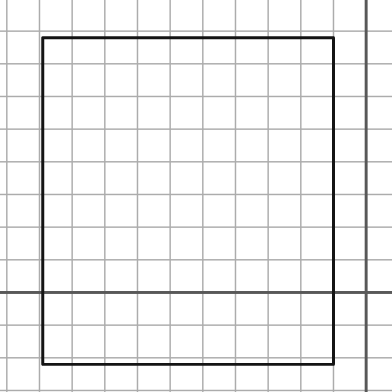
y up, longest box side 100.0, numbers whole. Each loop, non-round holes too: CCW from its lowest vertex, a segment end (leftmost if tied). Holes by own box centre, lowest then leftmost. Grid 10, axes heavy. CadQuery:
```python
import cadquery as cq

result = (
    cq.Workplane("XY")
    .moveTo(-99.0, -22.0)
    .lineTo(-10.0, -22.0)
    .lineTo(-10.0, 78.0)
    .lineTo(-99.0, 78.0)
    .close()
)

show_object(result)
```